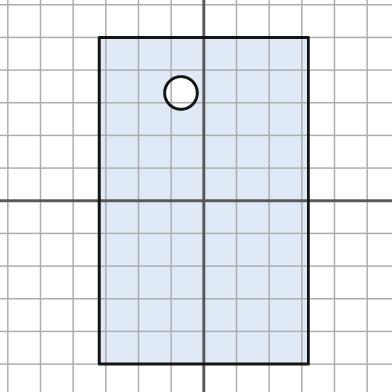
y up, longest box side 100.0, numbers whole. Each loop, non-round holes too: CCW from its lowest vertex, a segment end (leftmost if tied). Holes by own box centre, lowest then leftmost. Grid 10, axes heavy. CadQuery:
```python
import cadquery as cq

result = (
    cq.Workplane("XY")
    .moveTo(-32.0, -50.0)
    .lineTo(32.0, -50.0)
    .lineTo(32.0, 50.0)
    .lineTo(-32.0, 50.0)
    .close()
    .moveTo(-7.0, 33.0)
    .circle(5.0)
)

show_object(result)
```